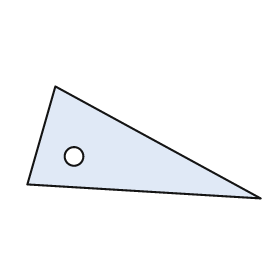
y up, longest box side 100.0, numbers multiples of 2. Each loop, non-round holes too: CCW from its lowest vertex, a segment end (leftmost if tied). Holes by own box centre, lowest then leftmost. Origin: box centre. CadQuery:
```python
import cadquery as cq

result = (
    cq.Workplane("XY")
    .moveTo(50.0, -24.0)
    .lineTo(-38.0, 24.0)
    .lineTo(-50.0, -18.0)
    .close()
    .moveTo(-30.0, -6.0)
    .circle(4.0)
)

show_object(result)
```